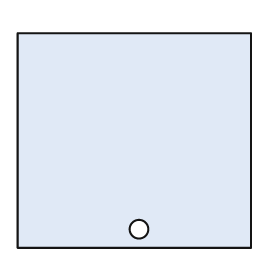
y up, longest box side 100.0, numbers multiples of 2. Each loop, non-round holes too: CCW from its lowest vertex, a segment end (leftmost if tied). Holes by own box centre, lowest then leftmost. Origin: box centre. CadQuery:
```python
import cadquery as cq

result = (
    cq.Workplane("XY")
    .moveTo(-50.0, -46.0)
    .lineTo(50.0, -46.0)
    .lineTo(50.0, 46.0)
    .lineTo(-50.0, 46.0)
    .close()
    .moveTo(2.0, -38.0)
    .circle(4.0)
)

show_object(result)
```